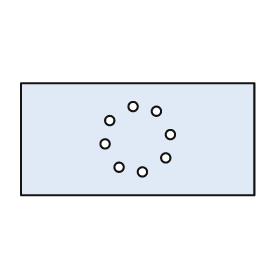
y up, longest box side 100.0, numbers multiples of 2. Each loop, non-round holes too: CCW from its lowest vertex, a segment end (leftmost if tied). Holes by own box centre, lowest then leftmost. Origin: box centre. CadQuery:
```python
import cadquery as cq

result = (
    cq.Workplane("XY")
    .moveTo(-50.0, -24.0)
    .lineTo(50.0, -24.0)
    .lineTo(50.0, 24.0)
    .lineTo(-50.0, 24.0)
    .close()
    .moveTo(2.0, -14.0)
    .circle(2.0)
    .moveTo(-8.0, -12.0)
    .circle(2.0)
    .moveTo(12.0, -8.0)
    .circle(2.0)
    .moveTo(-14.0, -2.0)
    .circle(2.0)
    .moveTo(14.0, 2.0)
    .circle(2.0)
    .moveTo(-12.0, 8.0)
    .circle(2.0)
    .moveTo(8.0, 12.0)
    .circle(2.0)
    .moveTo(-2.0, 14.0)
    .circle(2.0)
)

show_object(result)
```